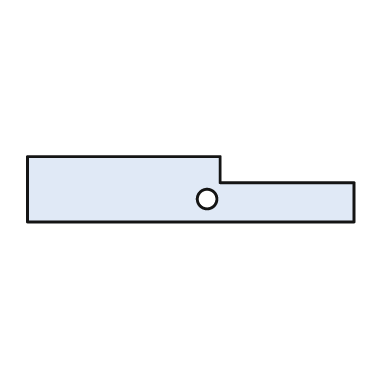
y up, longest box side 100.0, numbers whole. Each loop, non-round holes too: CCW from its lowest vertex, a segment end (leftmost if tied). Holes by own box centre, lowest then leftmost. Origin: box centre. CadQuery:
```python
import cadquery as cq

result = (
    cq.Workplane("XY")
    .moveTo(-50.0, -10.0)
    .lineTo(50.0, -10.0)
    .lineTo(50.0, 2.0)
    .lineTo(9.0, 2.0)
    .lineTo(9.0, 10.0)
    .lineTo(-50.0, 10.0)
    .close()
    .moveTo(5.0, -3.0)
    .circle(3.0)
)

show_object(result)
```